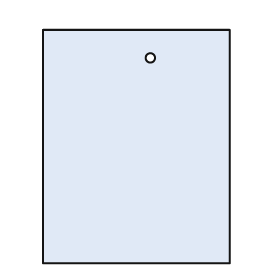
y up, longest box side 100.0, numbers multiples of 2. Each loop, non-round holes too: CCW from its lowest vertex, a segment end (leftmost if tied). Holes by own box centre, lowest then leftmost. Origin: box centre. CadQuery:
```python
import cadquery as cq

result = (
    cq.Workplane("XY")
    .moveTo(-40.0, -50.0)
    .lineTo(40.0, -50.0)
    .lineTo(40.0, 50.0)
    .lineTo(-40.0, 50.0)
    .close()
    .moveTo(6.0, 38.0)
    .circle(2.0)
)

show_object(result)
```